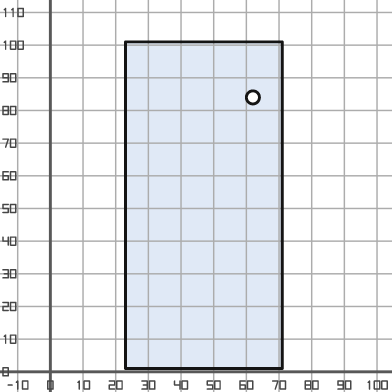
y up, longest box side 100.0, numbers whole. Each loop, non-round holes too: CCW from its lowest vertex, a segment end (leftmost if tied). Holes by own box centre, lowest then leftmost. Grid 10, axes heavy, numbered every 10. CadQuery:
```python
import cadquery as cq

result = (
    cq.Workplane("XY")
    .moveTo(23.0, 1.0)
    .lineTo(71.0, 1.0)
    .lineTo(71.0, 101.0)
    .lineTo(23.0, 101.0)
    .close()
    .moveTo(62.0, 84.0)
    .circle(2.0)
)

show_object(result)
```